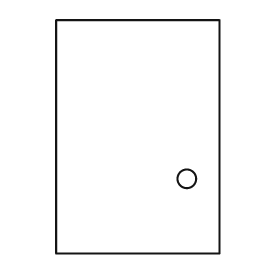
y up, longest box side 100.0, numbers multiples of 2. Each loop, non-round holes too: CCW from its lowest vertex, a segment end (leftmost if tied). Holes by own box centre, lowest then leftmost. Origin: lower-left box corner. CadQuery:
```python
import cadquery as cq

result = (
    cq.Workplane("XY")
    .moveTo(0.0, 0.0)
    .lineTo(70.0, 0.0)
    .lineTo(70.0, 100.0)
    .lineTo(0.0, 100.0)
    .close()
    .moveTo(56.0, 32.0)
    .circle(4.0)
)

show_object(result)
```